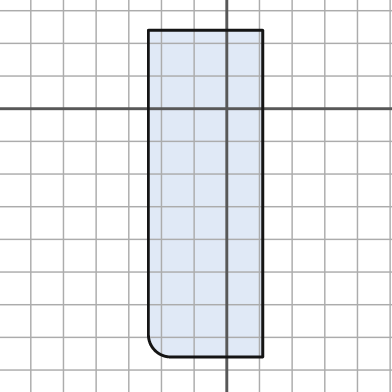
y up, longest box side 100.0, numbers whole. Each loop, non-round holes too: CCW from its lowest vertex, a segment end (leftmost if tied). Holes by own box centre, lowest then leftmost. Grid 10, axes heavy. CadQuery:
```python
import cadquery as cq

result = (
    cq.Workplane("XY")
    .moveTo(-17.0, -76.0)
    .lineTo(11.0, -76.0)
    .lineTo(11.0, 24.0)
    .lineTo(-24.0, 24.0)
    .lineTo(-24.0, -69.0)
    .threePointArc((-22.0, -74.0), (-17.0, -76.0))
    .close()
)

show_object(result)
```